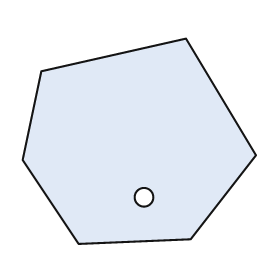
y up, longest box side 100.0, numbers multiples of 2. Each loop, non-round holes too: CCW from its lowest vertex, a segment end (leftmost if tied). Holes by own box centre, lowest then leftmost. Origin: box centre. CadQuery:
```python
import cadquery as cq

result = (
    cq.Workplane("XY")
    .moveTo(-26.0, -44.0)
    .lineTo(22.0, -42.0)
    .lineTo(50.0, -6.0)
    .lineTo(20.0, 44.0)
    .lineTo(-42.0, 30.0)
    .lineTo(-50.0, -8.0)
    .close()
    .moveTo(2.0, -24.0)
    .circle(4.0)
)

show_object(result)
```